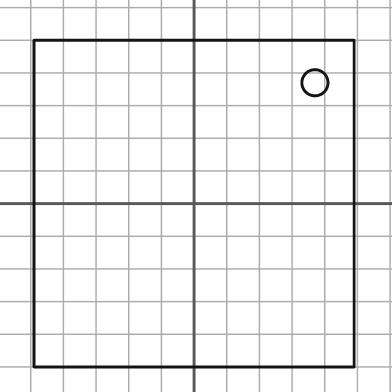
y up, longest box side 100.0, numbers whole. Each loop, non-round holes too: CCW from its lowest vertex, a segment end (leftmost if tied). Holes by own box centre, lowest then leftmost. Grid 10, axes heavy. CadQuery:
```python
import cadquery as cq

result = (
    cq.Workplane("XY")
    .moveTo(-49.0, -50.0)
    .lineTo(49.0, -50.0)
    .lineTo(49.0, 50.0)
    .lineTo(-49.0, 50.0)
    .close()
    .moveTo(37.0, 37.0)
    .circle(4.0)
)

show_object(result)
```